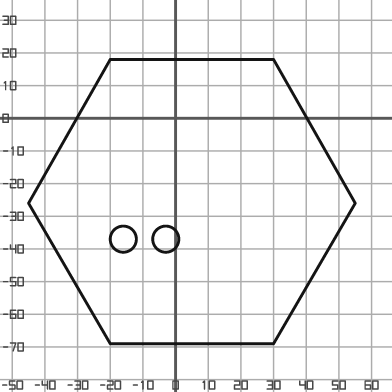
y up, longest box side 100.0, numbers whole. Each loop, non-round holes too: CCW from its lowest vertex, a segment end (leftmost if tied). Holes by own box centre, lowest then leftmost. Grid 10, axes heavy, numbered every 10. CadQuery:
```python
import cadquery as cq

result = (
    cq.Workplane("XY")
    .moveTo(-20.0, -69.0)
    .lineTo(30.0, -69.0)
    .lineTo(55.0, -26.0)
    .lineTo(30.0, 18.0)
    .lineTo(-20.0, 18.0)
    .lineTo(-45.0, -26.0)
    .close()
    .moveTo(-16.0, -37.0)
    .circle(4.0)
    .moveTo(-3.0, -37.0)
    .circle(4.0)
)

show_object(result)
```